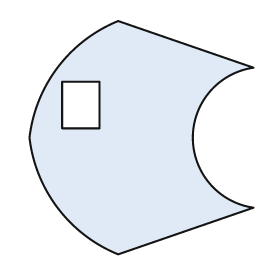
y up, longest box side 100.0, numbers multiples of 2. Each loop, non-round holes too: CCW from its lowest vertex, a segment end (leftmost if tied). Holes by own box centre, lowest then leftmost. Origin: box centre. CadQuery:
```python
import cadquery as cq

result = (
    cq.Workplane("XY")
    .moveTo(-10.0, -50.0)
    .lineTo(48.0, -30.0)
    .threePointArc((22.0, 0.0), (48.0, 30.0))
    .lineTo(-10.0, 50.0)
    .threePointArc((-36.0, 30.0), (-48.0, 0.0))
    .threePointArc((-36.0, -30.0), (-10.0, -50.0))
    .close()
    .moveTo(-34.0, 4.0)
    .lineTo(-18.0, 4.0)
    .lineTo(-18.0, 24.0)
    .lineTo(-34.0, 24.0)
    .close()
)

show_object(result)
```